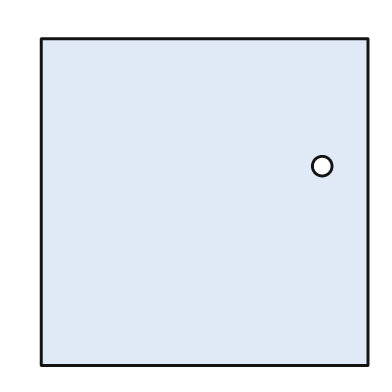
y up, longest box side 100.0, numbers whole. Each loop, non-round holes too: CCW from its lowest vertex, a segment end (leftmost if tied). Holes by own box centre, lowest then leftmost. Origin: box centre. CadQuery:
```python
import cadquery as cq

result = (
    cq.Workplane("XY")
    .moveTo(-50.0, -50.0)
    .lineTo(50.0, -50.0)
    .lineTo(50.0, 50.0)
    .lineTo(-50.0, 50.0)
    .close()
    .moveTo(36.0, 11.0)
    .circle(3.0)
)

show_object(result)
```